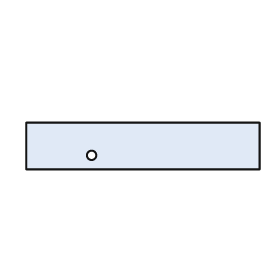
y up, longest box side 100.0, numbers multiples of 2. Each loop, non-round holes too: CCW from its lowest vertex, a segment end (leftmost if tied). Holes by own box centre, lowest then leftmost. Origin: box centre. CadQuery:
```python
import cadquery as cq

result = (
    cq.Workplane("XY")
    .moveTo(-50.0, -10.0)
    .lineTo(50.0, -10.0)
    .lineTo(50.0, 10.0)
    .lineTo(-50.0, 10.0)
    .close()
    .moveTo(-22.0, -4.0)
    .circle(2.0)
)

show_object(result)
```